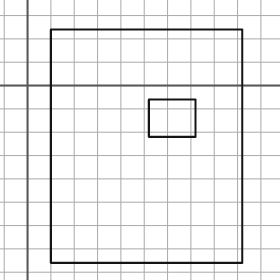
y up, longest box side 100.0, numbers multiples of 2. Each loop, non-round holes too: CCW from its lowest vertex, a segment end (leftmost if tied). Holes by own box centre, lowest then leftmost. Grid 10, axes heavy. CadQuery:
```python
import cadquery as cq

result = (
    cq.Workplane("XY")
    .moveTo(10.0, -76.0)
    .lineTo(92.0, -76.0)
    .lineTo(92.0, 24.0)
    .lineTo(10.0, 24.0)
    .close()
    .moveTo(52.0, -22.0)
    .lineTo(72.0, -22.0)
    .lineTo(72.0, -6.0)
    .lineTo(52.0, -6.0)
    .close()
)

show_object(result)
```